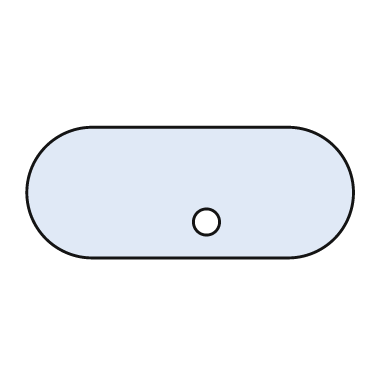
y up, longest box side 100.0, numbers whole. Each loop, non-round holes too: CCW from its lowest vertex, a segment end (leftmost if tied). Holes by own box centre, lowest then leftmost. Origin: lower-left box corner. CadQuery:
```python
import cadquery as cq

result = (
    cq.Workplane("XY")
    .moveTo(20.0, 0.0)
    .lineTo(80.0, 0.0)
    .threePointArc((100.0, 20.0), (80.0, 40.0))
    .lineTo(20.0, 40.0)
    .threePointArc((0.0, 20.0), (20.0, 0.0))
    .close()
    .moveTo(55.0, 11.0)
    .circle(4.0)
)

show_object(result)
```